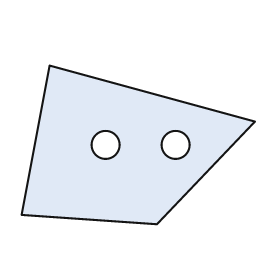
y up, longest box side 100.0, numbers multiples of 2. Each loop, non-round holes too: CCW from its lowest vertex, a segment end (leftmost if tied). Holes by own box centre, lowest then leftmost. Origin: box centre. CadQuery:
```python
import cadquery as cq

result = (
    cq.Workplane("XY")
    .moveTo(8.0, -34.0)
    .lineTo(50.0, 10.0)
    .lineTo(-38.0, 34.0)
    .lineTo(-50.0, -30.0)
    .close()
    .moveTo(-14.0, 0.0)
    .circle(6.0)
    .moveTo(16.0, 0.0)
    .circle(6.0)
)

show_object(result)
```